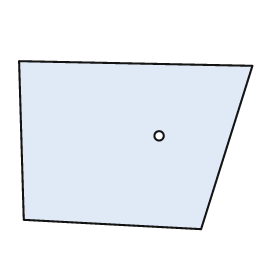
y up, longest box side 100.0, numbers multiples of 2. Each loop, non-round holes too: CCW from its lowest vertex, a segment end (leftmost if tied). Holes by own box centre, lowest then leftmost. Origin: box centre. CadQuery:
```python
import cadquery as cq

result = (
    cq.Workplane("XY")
    .moveTo(28.0, -36.0)
    .lineTo(50.0, 34.0)
    .lineTo(-50.0, 36.0)
    .lineTo(-48.0, -32.0)
    .close()
    .moveTo(10.0, 4.0)
    .circle(2.0)
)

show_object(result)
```